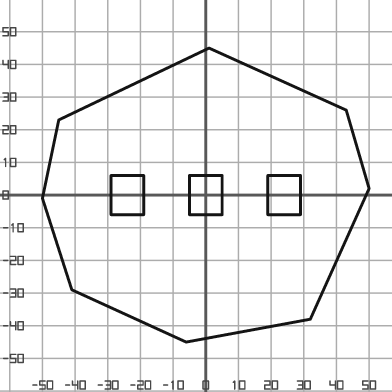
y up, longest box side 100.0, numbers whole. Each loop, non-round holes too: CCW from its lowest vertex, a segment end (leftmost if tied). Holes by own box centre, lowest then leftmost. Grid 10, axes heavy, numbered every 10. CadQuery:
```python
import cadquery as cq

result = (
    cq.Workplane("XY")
    .moveTo(-6.0, -45.0)
    .lineTo(32.0, -38.0)
    .lineTo(50.0, 2.0)
    .lineTo(43.0, 26.0)
    .lineTo(1.0, 45.0)
    .lineTo(-45.0, 23.0)
    .lineTo(-50.0, -1.0)
    .lineTo(-41.0, -29.0)
    .close()
    .moveTo(-29.0, -6.0)
    .lineTo(-19.0, -6.0)
    .lineTo(-19.0, 6.0)
    .lineTo(-29.0, 6.0)
    .close()
    .moveTo(-5.0, -6.0)
    .lineTo(5.0, -6.0)
    .lineTo(5.0, 6.0)
    .lineTo(-5.0, 6.0)
    .close()
    .moveTo(19.0, -6.0)
    .lineTo(29.0, -6.0)
    .lineTo(29.0, 6.0)
    .lineTo(19.0, 6.0)
    .close()
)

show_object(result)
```